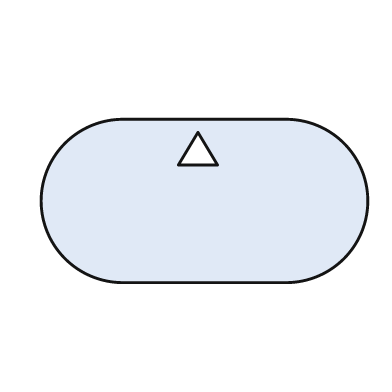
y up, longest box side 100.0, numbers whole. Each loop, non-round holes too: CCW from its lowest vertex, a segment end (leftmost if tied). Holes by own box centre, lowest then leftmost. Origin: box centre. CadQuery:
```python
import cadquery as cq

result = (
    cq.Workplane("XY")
    .moveTo(-25.0, -25.0)
    .lineTo(25.0, -25.0)
    .threePointArc((50.0, 0.0), (25.0, 25.0))
    .lineTo(-25.0, 25.0)
    .threePointArc((-50.0, 0.0), (-25.0, -25.0))
    .close()
    .moveTo(-8.0, 11.0)
    .lineTo(4.0, 11.0)
    .lineTo(-2.0, 21.0)
    .close()
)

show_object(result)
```